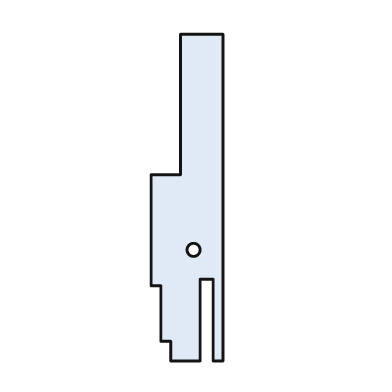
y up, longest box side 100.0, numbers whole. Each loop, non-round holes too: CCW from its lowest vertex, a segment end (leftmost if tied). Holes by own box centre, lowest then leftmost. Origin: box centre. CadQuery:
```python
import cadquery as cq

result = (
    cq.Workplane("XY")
    .moveTo(-5.0, -50.0)
    .lineTo(4.0, -50.0)
    .lineTo(4.0, -25.0)
    .lineTo(8.0, -25.0)
    .lineTo(8.0, -50.0)
    .lineTo(11.0, -50.0)
    .lineTo(11.0, 50.0)
    .lineTo(-2.0, 50.0)
    .lineTo(-2.0, 7.0)
    .lineTo(-11.0, 7.0)
    .lineTo(-11.0, -27.0)
    .lineTo(-8.0, -27.0)
    .lineTo(-8.0, -44.0)
    .lineTo(-5.0, -44.0)
    .close()
    .moveTo(2.0, -16.0)
    .circle(2.0)
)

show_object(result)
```